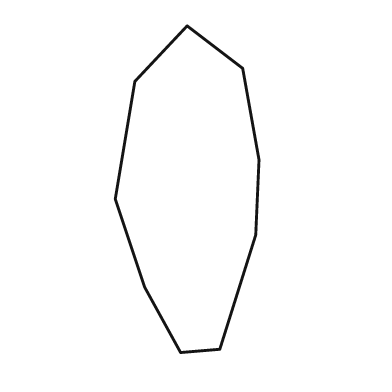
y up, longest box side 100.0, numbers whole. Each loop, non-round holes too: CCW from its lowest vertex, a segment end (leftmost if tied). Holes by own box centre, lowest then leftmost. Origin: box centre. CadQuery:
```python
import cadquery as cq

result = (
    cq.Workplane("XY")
    .moveTo(-2.0, -50.0)
    .lineTo(10.0, -49.0)
    .lineTo(21.0, -14.0)
    .lineTo(22.0, 9.0)
    .lineTo(17.0, 37.0)
    .lineTo(0.0, 50.0)
    .lineTo(-16.0, 33.0)
    .lineTo(-22.0, -3.0)
    .lineTo(-13.0, -30.0)
    .close()
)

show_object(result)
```